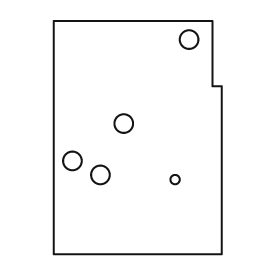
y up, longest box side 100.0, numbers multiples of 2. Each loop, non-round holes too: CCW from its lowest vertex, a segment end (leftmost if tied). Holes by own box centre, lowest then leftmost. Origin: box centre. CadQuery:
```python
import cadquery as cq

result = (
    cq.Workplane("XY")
    .moveTo(-36.0, -50.0)
    .lineTo(36.0, -50.0)
    .lineTo(36.0, 22.0)
    .lineTo(32.0, 22.0)
    .lineTo(32.0, 50.0)
    .lineTo(-36.0, 50.0)
    .close()
    .moveTo(16.0, -18.0)
    .circle(2.0)
    .moveTo(-16.0, -16.0)
    .circle(4.0)
    .moveTo(-28.0, -10.0)
    .circle(4.0)
    .moveTo(-6.0, 6.0)
    .circle(4.0)
    .moveTo(22.0, 42.0)
    .circle(4.0)
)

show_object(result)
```